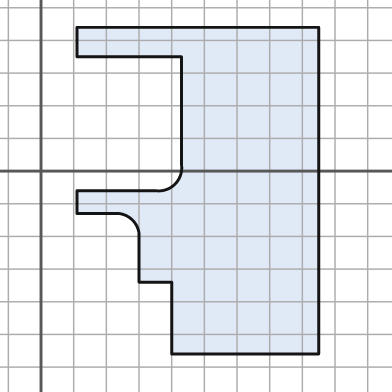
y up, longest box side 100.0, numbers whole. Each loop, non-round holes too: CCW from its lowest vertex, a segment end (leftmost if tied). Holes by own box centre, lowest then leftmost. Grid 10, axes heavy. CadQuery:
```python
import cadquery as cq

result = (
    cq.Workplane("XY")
    .moveTo(40.0, -56.0)
    .lineTo(85.0, -56.0)
    .lineTo(85.0, 44.0)
    .lineTo(11.0, 44.0)
    .lineTo(11.0, 35.0)
    .lineTo(43.0, 35.0)
    .lineTo(43.0, 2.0)
    .threePointArc((41.0, -4.0), (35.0, -6.0))
    .lineTo(11.0, -6.0)
    .lineTo(11.0, -13.0)
    .lineTo(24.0, -13.0)
    .threePointArc((28.0, -15.0), (30.0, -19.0))
    .lineTo(30.0, -34.0)
    .lineTo(40.0, -34.0)
    .close()
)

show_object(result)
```